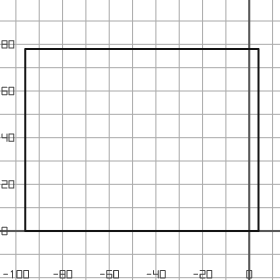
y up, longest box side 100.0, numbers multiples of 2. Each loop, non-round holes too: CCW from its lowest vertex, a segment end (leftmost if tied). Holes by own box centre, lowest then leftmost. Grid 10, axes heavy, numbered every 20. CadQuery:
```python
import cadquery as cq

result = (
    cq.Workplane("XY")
    .moveTo(-96.0, 0.0)
    .lineTo(4.0, 0.0)
    .lineTo(4.0, 78.0)
    .lineTo(-96.0, 78.0)
    .close()
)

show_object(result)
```